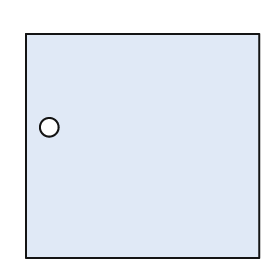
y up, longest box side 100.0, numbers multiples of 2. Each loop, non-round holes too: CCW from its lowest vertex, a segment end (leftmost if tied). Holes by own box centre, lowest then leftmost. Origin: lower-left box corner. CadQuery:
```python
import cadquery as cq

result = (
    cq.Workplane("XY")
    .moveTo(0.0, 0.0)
    .lineTo(100.0, 0.0)
    .lineTo(100.0, 96.0)
    .lineTo(0.0, 96.0)
    .close()
    .moveTo(10.0, 56.0)
    .circle(4.0)
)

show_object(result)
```